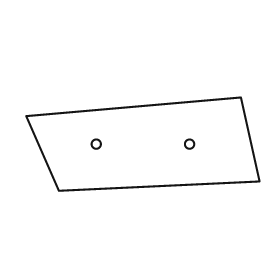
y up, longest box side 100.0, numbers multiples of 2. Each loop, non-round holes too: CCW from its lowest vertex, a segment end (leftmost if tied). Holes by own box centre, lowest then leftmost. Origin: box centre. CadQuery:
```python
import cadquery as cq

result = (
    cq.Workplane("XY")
    .moveTo(-36.0, -20.0)
    .lineTo(50.0, -16.0)
    .lineTo(42.0, 20.0)
    .lineTo(-50.0, 12.0)
    .close()
    .moveTo(-20.0, 0.0)
    .circle(2.0)
    .moveTo(20.0, 0.0)
    .circle(2.0)
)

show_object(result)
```